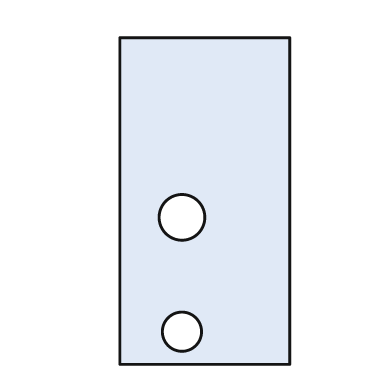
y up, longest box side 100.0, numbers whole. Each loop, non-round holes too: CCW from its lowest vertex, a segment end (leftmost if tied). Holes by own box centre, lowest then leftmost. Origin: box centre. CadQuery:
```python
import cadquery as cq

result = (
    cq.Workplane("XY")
    .moveTo(-26.0, -50.0)
    .lineTo(26.0, -50.0)
    .lineTo(26.0, 50.0)
    .lineTo(-26.0, 50.0)
    .close()
    .moveTo(-7.0, -40.0)
    .circle(6.0)
    .moveTo(-7.0, -5.0)
    .circle(7.0)
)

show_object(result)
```